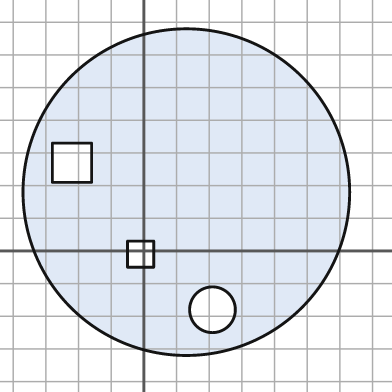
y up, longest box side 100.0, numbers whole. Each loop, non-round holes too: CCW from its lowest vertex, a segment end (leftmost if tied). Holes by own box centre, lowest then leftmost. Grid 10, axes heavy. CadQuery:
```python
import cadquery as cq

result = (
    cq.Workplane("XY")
    .moveTo(13.0, 18.0)
    .circle(50.0)
    .moveTo(21.0, -18.0)
    .circle(7.0)
    .moveTo(-5.0, -5.0)
    .lineTo(3.0, -5.0)
    .lineTo(3.0, 3.0)
    .lineTo(-5.0, 3.0)
    .close()
    .moveTo(-28.0, 21.0)
    .lineTo(-16.0, 21.0)
    .lineTo(-16.0, 33.0)
    .lineTo(-28.0, 33.0)
    .close()
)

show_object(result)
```